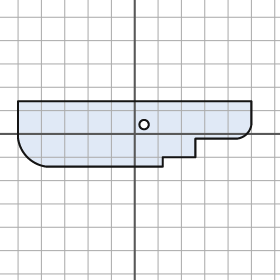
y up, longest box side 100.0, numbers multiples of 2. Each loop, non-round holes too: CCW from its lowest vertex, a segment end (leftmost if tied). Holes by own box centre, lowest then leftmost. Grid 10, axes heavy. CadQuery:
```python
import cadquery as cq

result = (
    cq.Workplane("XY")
    .moveTo(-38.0, -14.0)
    .lineTo(12.0, -14.0)
    .lineTo(12.0, -10.0)
    .lineTo(26.0, -10.0)
    .lineTo(26.0, -2.0)
    .lineTo(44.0, -2.0)
    .threePointArc((48.0, 0.0), (50.0, 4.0))
    .lineTo(50.0, 14.0)
    .lineTo(-50.0, 14.0)
    .lineTo(-50.0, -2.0)
    .threePointArc((-46.0, -10.0), (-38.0, -14.0))
    .close()
    .moveTo(4.0, 4.0)
    .circle(2.0)
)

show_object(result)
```